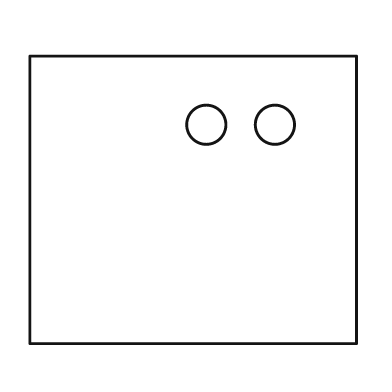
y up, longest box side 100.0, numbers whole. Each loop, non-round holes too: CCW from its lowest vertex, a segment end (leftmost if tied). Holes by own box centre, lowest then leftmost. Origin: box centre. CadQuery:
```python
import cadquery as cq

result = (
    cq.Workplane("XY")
    .moveTo(-50.0, -44.0)
    .lineTo(50.0, -44.0)
    .lineTo(50.0, 44.0)
    .lineTo(-50.0, 44.0)
    .close()
    .moveTo(4.0, 23.0)
    .circle(6.0)
    .moveTo(25.0, 23.0)
    .circle(6.0)
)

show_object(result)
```